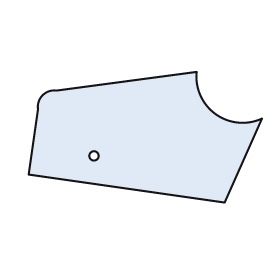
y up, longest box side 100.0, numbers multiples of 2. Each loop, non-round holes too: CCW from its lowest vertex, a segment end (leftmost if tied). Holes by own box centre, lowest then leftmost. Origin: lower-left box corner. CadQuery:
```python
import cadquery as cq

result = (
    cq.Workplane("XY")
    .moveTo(84.0, 0.0)
    .lineTo(100.0, 36.0)
    .threePointArc((80.0, 38.0), (72.0, 56.0))
    .lineTo(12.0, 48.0)
    .threePointArc((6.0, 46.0), (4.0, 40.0))
    .lineTo(0.0, 12.0)
    .close()
    .moveTo(28.0, 20.0)
    .circle(2.0)
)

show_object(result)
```